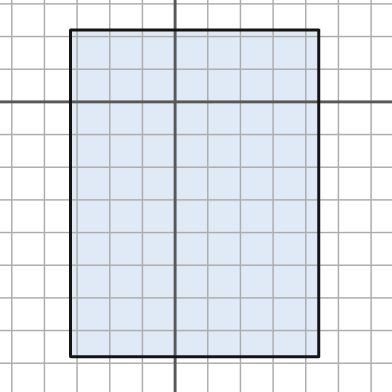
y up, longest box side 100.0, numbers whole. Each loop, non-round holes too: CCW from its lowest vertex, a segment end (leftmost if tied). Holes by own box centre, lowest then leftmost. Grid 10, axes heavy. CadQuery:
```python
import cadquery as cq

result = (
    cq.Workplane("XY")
    .moveTo(-32.0, -78.0)
    .lineTo(44.0, -78.0)
    .lineTo(44.0, 22.0)
    .lineTo(-32.0, 22.0)
    .close()
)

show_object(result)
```